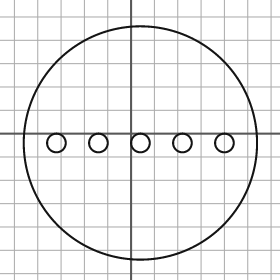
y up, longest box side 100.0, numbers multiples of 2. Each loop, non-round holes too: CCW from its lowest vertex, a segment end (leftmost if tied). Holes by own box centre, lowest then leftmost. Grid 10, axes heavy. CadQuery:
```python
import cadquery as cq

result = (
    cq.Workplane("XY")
    .moveTo(4.0, -4.0)
    .circle(50.0)
    .moveTo(-32.0, -4.0)
    .circle(4.0)
    .moveTo(-14.0, -4.0)
    .circle(4.0)
    .moveTo(4.0, -4.0)
    .circle(4.0)
    .moveTo(22.0, -4.0)
    .circle(4.0)
    .moveTo(40.0, -4.0)
    .circle(4.0)
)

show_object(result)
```